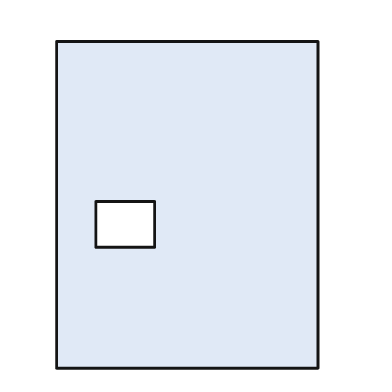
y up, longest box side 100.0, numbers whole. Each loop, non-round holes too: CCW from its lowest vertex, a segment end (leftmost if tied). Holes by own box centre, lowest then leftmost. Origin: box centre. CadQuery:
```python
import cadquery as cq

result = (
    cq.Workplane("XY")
    .moveTo(-40.0, -50.0)
    .lineTo(40.0, -50.0)
    .lineTo(40.0, 50.0)
    .lineTo(-40.0, 50.0)
    .close()
    .moveTo(-28.0, -13.0)
    .lineTo(-10.0, -13.0)
    .lineTo(-10.0, 1.0)
    .lineTo(-28.0, 1.0)
    .close()
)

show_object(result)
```